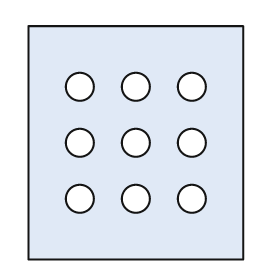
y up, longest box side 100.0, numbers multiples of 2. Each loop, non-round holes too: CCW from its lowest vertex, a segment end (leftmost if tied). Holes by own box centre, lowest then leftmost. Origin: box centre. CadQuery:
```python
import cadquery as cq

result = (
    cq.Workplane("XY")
    .moveTo(-46.0, -50.0)
    .lineTo(46.0, -50.0)
    .lineTo(46.0, 50.0)
    .lineTo(-46.0, 50.0)
    .close()
    .moveTo(-24.0, -24.0)
    .circle(6.0)
    .moveTo(0.0, -24.0)
    .circle(6.0)
    .moveTo(24.0, -24.0)
    .circle(6.0)
    .moveTo(-24.0, 0.0)
    .circle(6.0)
    .moveTo(0.0, 0.0)
    .circle(6.0)
    .moveTo(24.0, 0.0)
    .circle(6.0)
    .moveTo(-24.0, 24.0)
    .circle(6.0)
    .moveTo(0.0, 24.0)
    .circle(6.0)
    .moveTo(24.0, 24.0)
    .circle(6.0)
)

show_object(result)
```